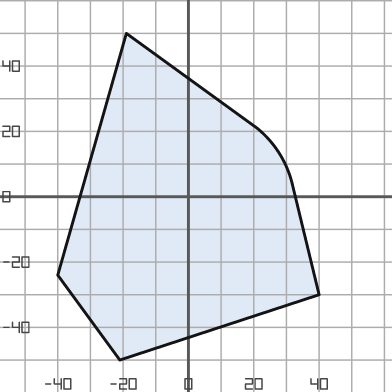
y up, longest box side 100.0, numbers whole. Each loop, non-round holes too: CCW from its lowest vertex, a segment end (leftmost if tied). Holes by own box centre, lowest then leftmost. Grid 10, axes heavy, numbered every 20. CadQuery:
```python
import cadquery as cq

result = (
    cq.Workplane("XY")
    .moveTo(-21.0, -50.0)
    .lineTo(40.0, -30.0)
    .lineTo(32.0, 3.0)
    .threePointArc((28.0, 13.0), (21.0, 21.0))
    .lineTo(-19.0, 50.0)
    .lineTo(-40.0, -24.0)
    .close()
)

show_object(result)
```